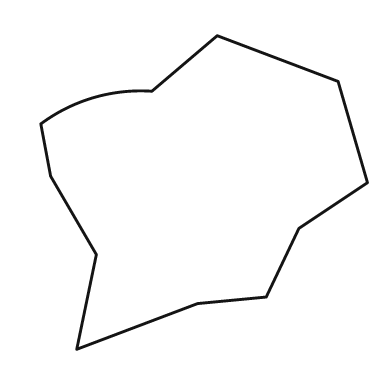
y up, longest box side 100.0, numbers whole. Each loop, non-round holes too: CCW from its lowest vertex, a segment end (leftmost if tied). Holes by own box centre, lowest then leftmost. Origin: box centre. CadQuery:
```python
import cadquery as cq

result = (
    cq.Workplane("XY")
    .moveTo(-39.0, -48.0)
    .lineTo(-2.0, -34.0)
    .lineTo(19.0, -32.0)
    .lineTo(29.0, -11.0)
    .lineTo(50.0, 3.0)
    .lineTo(41.0, 34.0)
    .lineTo(4.0, 48.0)
    .lineTo(-16.0, 31.0)
    .threePointArc((-34.0, 29.0), (-50.0, 21.0))
    .lineTo(-47.0, 5.0)
    .lineTo(-33.0, -19.0)
    .close()
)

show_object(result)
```